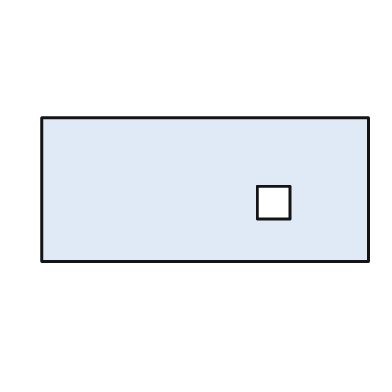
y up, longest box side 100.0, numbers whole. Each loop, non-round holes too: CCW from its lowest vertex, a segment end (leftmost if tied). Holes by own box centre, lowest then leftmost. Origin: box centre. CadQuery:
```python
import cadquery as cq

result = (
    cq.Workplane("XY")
    .moveTo(-50.0, -22.0)
    .lineTo(50.0, -22.0)
    .lineTo(50.0, 22.0)
    .lineTo(-50.0, 22.0)
    .close()
    .moveTo(16.0, -9.0)
    .lineTo(26.0, -9.0)
    .lineTo(26.0, 1.0)
    .lineTo(16.0, 1.0)
    .close()
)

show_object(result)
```